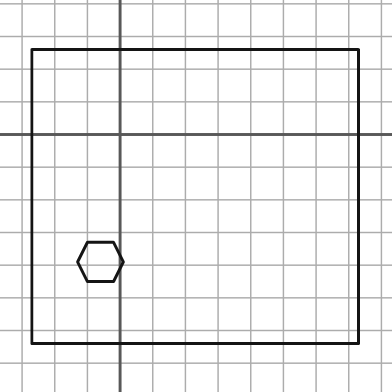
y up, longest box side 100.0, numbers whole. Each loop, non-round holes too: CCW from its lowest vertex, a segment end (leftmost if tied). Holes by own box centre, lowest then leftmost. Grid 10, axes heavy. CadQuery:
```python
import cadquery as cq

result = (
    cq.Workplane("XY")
    .moveTo(-27.0, -64.0)
    .lineTo(73.0, -64.0)
    .lineTo(73.0, 26.0)
    .lineTo(-27.0, 26.0)
    .close()
    .moveTo(-10.0, -45.0)
    .lineTo(-2.0, -45.0)
    .lineTo(1.0, -39.0)
    .lineTo(-2.0, -33.0)
    .lineTo(-10.0, -33.0)
    .lineTo(-13.0, -39.0)
    .close()
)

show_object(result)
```